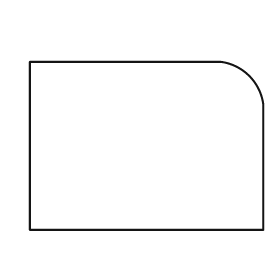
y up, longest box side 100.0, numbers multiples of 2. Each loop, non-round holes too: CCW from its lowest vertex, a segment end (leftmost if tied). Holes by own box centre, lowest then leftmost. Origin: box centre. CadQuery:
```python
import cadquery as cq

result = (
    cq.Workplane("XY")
    .moveTo(-50.0, -36.0)
    .lineTo(50.0, -36.0)
    .lineTo(50.0, 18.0)
    .threePointArc((44.0, 30.0), (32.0, 36.0))
    .lineTo(-50.0, 36.0)
    .close()
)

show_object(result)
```